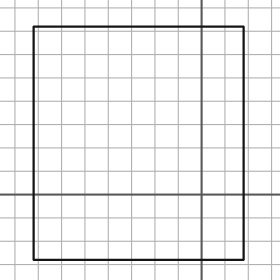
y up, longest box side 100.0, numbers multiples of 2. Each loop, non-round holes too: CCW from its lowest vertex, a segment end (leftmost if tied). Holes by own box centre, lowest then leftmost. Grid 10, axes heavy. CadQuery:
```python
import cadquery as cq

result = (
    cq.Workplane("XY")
    .moveTo(-72.0, -28.0)
    .lineTo(18.0, -28.0)
    .lineTo(18.0, 72.0)
    .lineTo(-72.0, 72.0)
    .close()
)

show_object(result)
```